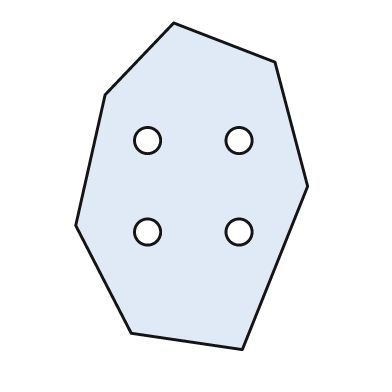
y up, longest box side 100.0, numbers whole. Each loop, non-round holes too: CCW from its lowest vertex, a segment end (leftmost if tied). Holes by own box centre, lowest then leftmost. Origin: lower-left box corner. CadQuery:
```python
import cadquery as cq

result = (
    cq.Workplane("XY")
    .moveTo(51.0, 0.0)
    .lineTo(71.0, 50.0)
    .lineTo(61.0, 88.0)
    .lineTo(30.0, 100.0)
    .lineTo(9.0, 78.0)
    .lineTo(0.0, 38.0)
    .lineTo(17.0, 5.0)
    .close()
    .moveTo(22.0, 36.0)
    .circle(4.0)
    .moveTo(50.0, 36.0)
    .circle(4.0)
    .moveTo(22.0, 64.0)
    .circle(4.0)
    .moveTo(50.0, 64.0)
    .circle(4.0)
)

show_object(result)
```